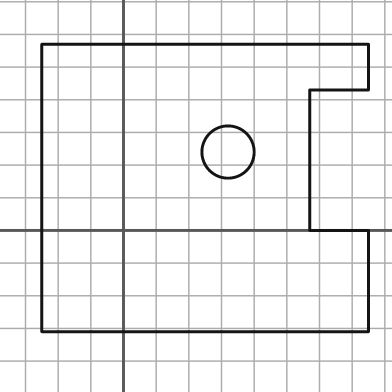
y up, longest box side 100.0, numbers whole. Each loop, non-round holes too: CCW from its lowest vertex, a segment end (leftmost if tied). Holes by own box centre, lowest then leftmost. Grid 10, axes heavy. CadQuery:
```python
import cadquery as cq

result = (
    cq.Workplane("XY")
    .moveTo(-25.0, -31.0)
    .lineTo(75.0, -31.0)
    .lineTo(75.0, 0.0)
    .lineTo(57.0, 0.0)
    .lineTo(57.0, 43.0)
    .lineTo(75.0, 43.0)
    .lineTo(75.0, 57.0)
    .lineTo(-25.0, 57.0)
    .close()
    .moveTo(32.0, 24.0)
    .circle(8.0)
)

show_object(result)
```